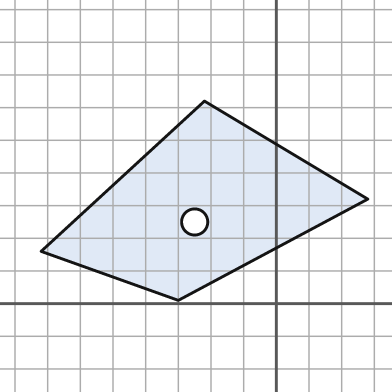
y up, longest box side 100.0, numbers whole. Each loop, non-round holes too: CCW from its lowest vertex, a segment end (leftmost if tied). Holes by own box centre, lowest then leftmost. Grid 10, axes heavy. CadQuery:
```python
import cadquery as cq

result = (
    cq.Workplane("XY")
    .moveTo(-30.0, 1.0)
    .lineTo(28.0, 32.0)
    .lineTo(-22.0, 62.0)
    .lineTo(-72.0, 16.0)
    .close()
    .moveTo(-25.0, 25.0)
    .circle(4.0)
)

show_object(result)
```